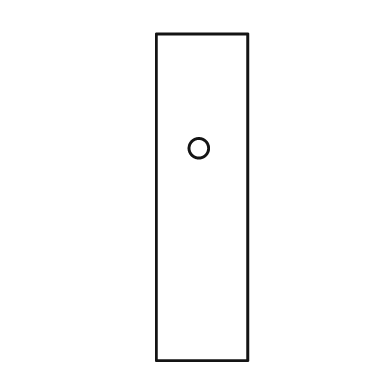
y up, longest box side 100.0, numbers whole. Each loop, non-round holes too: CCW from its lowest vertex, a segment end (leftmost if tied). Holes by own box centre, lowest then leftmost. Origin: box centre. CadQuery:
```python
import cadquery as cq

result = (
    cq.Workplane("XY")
    .moveTo(-14.0, -50.0)
    .lineTo(14.0, -50.0)
    .lineTo(14.0, 50.0)
    .lineTo(-14.0, 50.0)
    .close()
    .moveTo(-1.0, 15.0)
    .circle(3.0)
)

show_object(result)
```